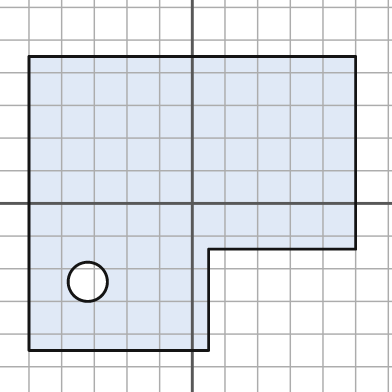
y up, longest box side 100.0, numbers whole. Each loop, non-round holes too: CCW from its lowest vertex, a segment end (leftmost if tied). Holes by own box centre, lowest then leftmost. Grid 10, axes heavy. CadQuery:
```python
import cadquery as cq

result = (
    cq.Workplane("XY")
    .moveTo(-50.0, -45.0)
    .lineTo(5.0, -45.0)
    .lineTo(5.0, -14.0)
    .lineTo(50.0, -14.0)
    .lineTo(50.0, 45.0)
    .lineTo(-50.0, 45.0)
    .close()
    .moveTo(-32.0, -24.0)
    .circle(6.0)
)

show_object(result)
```